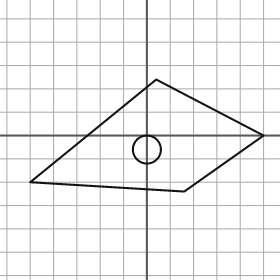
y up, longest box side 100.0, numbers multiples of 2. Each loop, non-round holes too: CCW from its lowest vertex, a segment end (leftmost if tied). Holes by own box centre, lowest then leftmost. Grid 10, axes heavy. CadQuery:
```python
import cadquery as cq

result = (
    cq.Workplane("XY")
    .moveTo(16.0, -24.0)
    .lineTo(50.0, 0.0)
    .lineTo(4.0, 24.0)
    .lineTo(-50.0, -20.0)
    .close()
    .moveTo(0.0, -6.0)
    .circle(6.0)
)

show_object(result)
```